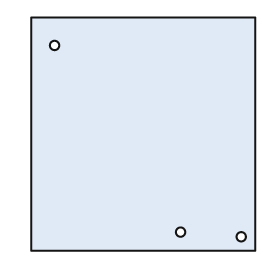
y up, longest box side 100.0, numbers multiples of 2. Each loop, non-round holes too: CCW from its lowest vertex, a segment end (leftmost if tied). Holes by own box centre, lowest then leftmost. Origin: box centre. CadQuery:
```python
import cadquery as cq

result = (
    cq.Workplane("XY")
    .moveTo(-48.0, -50.0)
    .lineTo(48.0, -50.0)
    .lineTo(48.0, 50.0)
    .lineTo(-48.0, 50.0)
    .close()
    .moveTo(42.0, -44.0)
    .circle(2.0)
    .moveTo(16.0, -42.0)
    .circle(2.0)
    .moveTo(-38.0, 38.0)
    .circle(2.0)
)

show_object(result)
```